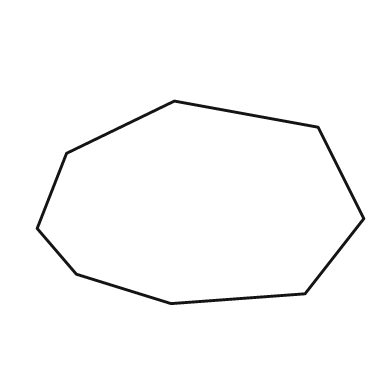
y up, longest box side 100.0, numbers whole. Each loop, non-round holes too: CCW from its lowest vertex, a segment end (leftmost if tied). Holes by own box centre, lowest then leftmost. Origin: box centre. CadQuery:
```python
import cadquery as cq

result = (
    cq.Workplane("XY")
    .moveTo(-9.0, -31.0)
    .lineTo(32.0, -28.0)
    .lineTo(50.0, -5.0)
    .lineTo(36.0, 23.0)
    .lineTo(-8.0, 31.0)
    .lineTo(-41.0, 15.0)
    .lineTo(-50.0, -8.0)
    .lineTo(-38.0, -22.0)
    .close()
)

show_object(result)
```